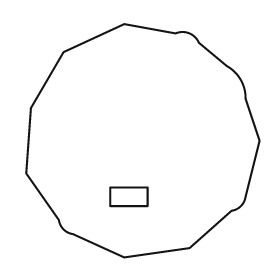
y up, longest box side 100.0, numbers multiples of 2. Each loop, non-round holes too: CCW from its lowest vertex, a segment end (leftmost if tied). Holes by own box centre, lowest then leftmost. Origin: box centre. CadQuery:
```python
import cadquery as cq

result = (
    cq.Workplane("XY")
    .moveTo(-8.0, -50.0)
    .lineTo(20.0, -46.0)
    .lineTo(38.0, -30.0)
    .threePointArc((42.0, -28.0), (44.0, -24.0))
    .lineTo(50.0, 0.0)
    .lineTo(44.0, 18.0)
    .threePointArc((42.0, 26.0), (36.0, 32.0))
    .lineTo(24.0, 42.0)
    .threePointArc((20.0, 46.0), (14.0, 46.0))
    .lineTo(-8.0, 50.0)
    .lineTo(-34.0, 38.0)
    .lineTo(-48.0, 14.0)
    .lineTo(-50.0, -14.0)
    .lineTo(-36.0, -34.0)
    .threePointArc((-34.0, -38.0), (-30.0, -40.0))
    .close()
    .moveTo(-14.0, -28.0)
    .lineTo(2.0, -28.0)
    .lineTo(2.0, -20.0)
    .lineTo(-14.0, -20.0)
    .close()
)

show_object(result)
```